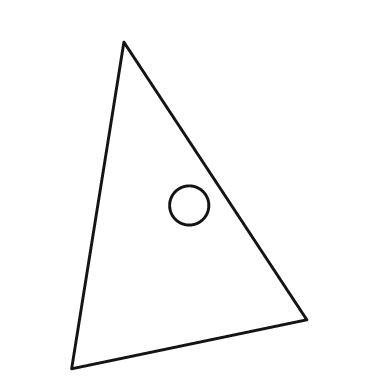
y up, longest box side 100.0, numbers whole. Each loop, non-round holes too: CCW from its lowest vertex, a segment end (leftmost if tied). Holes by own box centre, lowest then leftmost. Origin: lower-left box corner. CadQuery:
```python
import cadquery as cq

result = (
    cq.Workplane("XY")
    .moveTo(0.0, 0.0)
    .lineTo(72.0, 15.0)
    .lineTo(16.0, 100.0)
    .close()
    .moveTo(36.0, 50.0)
    .circle(6.0)
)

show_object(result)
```